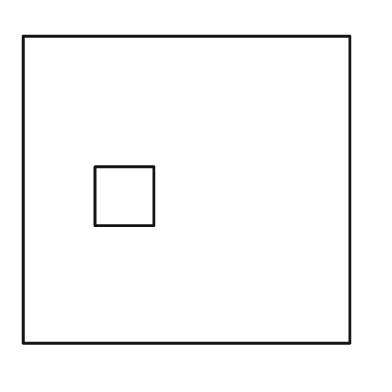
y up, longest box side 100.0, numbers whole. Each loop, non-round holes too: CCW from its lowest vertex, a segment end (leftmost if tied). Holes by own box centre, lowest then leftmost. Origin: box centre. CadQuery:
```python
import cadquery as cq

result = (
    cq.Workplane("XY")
    .moveTo(-50.0, -47.0)
    .lineTo(50.0, -47.0)
    .lineTo(50.0, 47.0)
    .lineTo(-50.0, 47.0)
    .close()
    .moveTo(-28.0, -11.0)
    .lineTo(-10.0, -11.0)
    .lineTo(-10.0, 7.0)
    .lineTo(-28.0, 7.0)
    .close()
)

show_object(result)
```